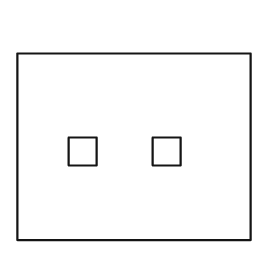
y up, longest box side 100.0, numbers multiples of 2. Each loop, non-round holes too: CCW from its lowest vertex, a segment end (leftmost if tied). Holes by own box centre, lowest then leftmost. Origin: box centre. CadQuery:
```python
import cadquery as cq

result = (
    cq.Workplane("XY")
    .moveTo(-50.0, -40.0)
    .lineTo(50.0, -40.0)
    .lineTo(50.0, 40.0)
    .lineTo(-50.0, 40.0)
    .close()
    .moveTo(-28.0, -8.0)
    .lineTo(-16.0, -8.0)
    .lineTo(-16.0, 4.0)
    .lineTo(-28.0, 4.0)
    .close()
    .moveTo(8.0, -8.0)
    .lineTo(20.0, -8.0)
    .lineTo(20.0, 4.0)
    .lineTo(8.0, 4.0)
    .close()
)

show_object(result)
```